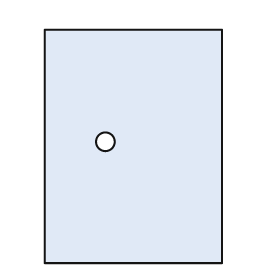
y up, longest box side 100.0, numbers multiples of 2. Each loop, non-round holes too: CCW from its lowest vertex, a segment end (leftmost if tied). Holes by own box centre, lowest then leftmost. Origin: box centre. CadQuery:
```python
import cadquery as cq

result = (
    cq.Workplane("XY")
    .moveTo(-38.0, -50.0)
    .lineTo(38.0, -50.0)
    .lineTo(38.0, 50.0)
    .lineTo(-38.0, 50.0)
    .close()
    .moveTo(-12.0, 2.0)
    .circle(4.0)
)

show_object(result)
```